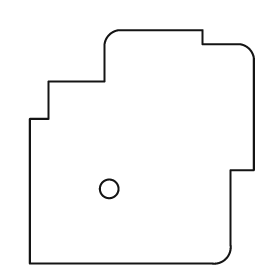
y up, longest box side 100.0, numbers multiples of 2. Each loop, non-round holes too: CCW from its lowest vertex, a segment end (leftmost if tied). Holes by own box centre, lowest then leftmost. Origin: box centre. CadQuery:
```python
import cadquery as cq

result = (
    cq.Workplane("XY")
    .moveTo(-48.0, -50.0)
    .lineTo(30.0, -50.0)
    .threePointArc((36.0, -48.0), (38.0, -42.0))
    .lineTo(38.0, -10.0)
    .lineTo(48.0, -10.0)
    .lineTo(48.0, 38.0)
    .threePointArc((46.0, 42.0), (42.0, 44.0))
    .lineTo(26.0, 44.0)
    .lineTo(26.0, 50.0)
    .lineTo(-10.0, 50.0)
    .threePointArc((-14.0, 48.0), (-16.0, 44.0))
    .lineTo(-16.0, 28.0)
    .lineTo(-40.0, 28.0)
    .lineTo(-40.0, 12.0)
    .lineTo(-48.0, 12.0)
    .close()
    .moveTo(-14.0, -18.0)
    .circle(4.0)
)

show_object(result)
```